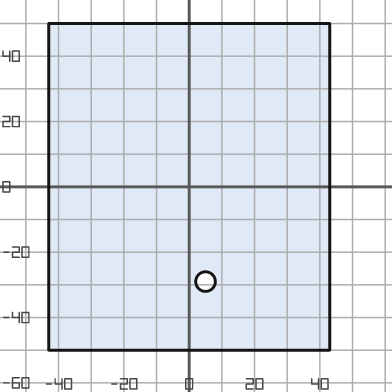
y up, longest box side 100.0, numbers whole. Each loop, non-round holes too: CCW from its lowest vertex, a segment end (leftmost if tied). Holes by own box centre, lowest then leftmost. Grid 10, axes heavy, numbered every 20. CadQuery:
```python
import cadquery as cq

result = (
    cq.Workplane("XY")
    .moveTo(-43.0, -50.0)
    .lineTo(43.0, -50.0)
    .lineTo(43.0, 50.0)
    .lineTo(-43.0, 50.0)
    .close()
    .moveTo(5.0, -29.0)
    .circle(3.0)
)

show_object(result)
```